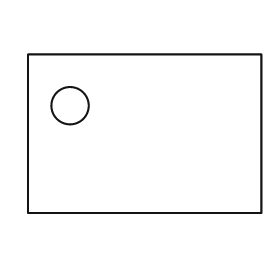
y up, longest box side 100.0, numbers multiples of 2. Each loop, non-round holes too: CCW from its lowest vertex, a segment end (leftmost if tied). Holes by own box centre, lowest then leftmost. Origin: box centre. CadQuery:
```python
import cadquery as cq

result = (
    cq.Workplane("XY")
    .moveTo(-50.0, -34.0)
    .lineTo(50.0, -34.0)
    .lineTo(50.0, 34.0)
    .lineTo(-50.0, 34.0)
    .close()
    .moveTo(-32.0, 12.0)
    .circle(8.0)
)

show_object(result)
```